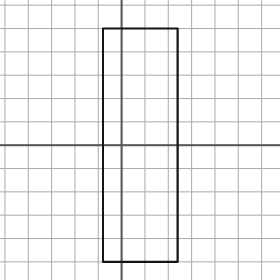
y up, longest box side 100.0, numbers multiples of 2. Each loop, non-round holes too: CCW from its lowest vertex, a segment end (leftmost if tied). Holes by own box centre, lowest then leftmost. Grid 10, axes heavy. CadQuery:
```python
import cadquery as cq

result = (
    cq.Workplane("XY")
    .moveTo(-8.0, -50.0)
    .lineTo(24.0, -50.0)
    .lineTo(24.0, 50.0)
    .lineTo(-8.0, 50.0)
    .close()
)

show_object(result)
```